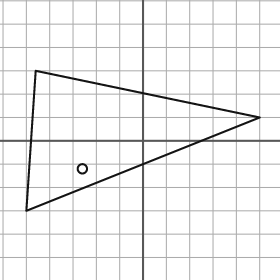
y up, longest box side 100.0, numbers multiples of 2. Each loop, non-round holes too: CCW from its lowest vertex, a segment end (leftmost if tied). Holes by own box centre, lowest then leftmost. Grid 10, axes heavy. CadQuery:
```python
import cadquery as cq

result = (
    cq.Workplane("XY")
    .moveTo(-50.0, -30.0)
    .lineTo(50.0, 10.0)
    .lineTo(-46.0, 30.0)
    .close()
    .moveTo(-26.0, -12.0)
    .circle(2.0)
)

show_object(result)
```